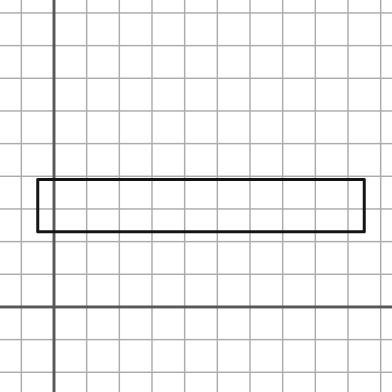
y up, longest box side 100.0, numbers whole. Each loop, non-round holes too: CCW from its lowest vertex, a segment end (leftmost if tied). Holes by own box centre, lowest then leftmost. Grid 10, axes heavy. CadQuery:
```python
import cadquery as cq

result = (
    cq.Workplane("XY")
    .moveTo(-5.0, 23.0)
    .lineTo(95.0, 23.0)
    .lineTo(95.0, 39.0)
    .lineTo(-5.0, 39.0)
    .close()
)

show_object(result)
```